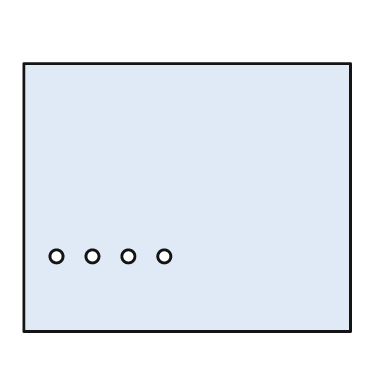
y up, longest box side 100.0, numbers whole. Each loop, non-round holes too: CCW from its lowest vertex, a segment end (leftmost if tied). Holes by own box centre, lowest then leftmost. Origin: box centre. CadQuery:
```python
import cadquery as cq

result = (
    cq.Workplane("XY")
    .moveTo(-50.0, -41.0)
    .lineTo(50.0, -41.0)
    .lineTo(50.0, 41.0)
    .lineTo(-50.0, 41.0)
    .close()
    .moveTo(-40.0, -18.0)
    .circle(2.0)
    .moveTo(-29.0, -18.0)
    .circle(2.0)
    .moveTo(-18.0, -18.0)
    .circle(2.0)
    .moveTo(-7.0, -18.0)
    .circle(2.0)
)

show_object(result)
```